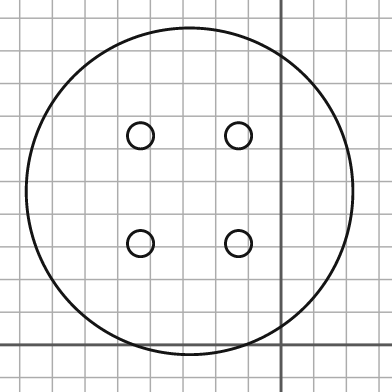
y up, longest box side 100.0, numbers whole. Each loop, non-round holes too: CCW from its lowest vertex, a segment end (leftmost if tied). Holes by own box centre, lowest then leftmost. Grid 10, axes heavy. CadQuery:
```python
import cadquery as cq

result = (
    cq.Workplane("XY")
    .moveTo(-28.0, 47.0)
    .circle(50.0)
    .moveTo(-43.0, 31.0)
    .circle(4.0)
    .moveTo(-13.0, 31.0)
    .circle(4.0)
    .moveTo(-43.0, 64.0)
    .circle(4.0)
    .moveTo(-13.0, 64.0)
    .circle(4.0)
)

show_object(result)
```